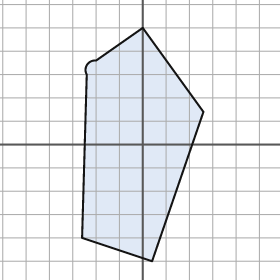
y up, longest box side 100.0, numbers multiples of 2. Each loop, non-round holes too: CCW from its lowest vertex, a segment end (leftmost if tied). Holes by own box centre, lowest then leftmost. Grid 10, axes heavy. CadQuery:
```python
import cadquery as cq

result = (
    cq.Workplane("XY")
    .moveTo(4.0, -50.0)
    .lineTo(26.0, 14.0)
    .lineTo(0.0, 50.0)
    .lineTo(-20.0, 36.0)
    .threePointArc((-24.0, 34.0), (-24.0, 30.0))
    .lineTo(-26.0, -40.0)
    .close()
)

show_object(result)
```